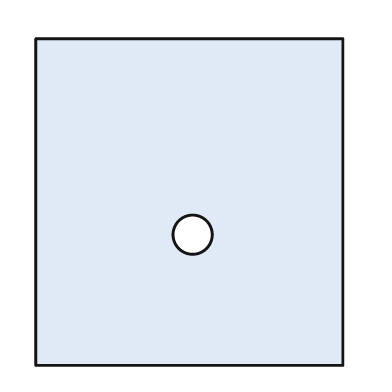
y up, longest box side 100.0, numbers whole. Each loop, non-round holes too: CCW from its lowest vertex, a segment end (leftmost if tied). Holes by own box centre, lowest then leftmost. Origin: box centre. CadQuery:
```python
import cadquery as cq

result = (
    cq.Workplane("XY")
    .moveTo(-47.0, -50.0)
    .lineTo(47.0, -50.0)
    .lineTo(47.0, 50.0)
    .lineTo(-47.0, 50.0)
    .close()
    .moveTo(1.0, -10.0)
    .circle(6.0)
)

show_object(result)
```